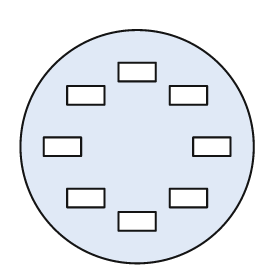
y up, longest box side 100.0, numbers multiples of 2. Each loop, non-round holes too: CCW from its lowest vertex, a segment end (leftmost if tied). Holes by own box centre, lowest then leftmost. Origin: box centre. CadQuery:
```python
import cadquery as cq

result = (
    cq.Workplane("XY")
    .moveTo(0.0, 0.0)
    .circle(50.0)
    .moveTo(-8.0, -36.0)
    .lineTo(8.0, -36.0)
    .lineTo(8.0, -28.0)
    .lineTo(-8.0, -28.0)
    .close()
    .moveTo(-30.0, -26.0)
    .lineTo(-14.0, -26.0)
    .lineTo(-14.0, -18.0)
    .lineTo(-30.0, -18.0)
    .close()
    .moveTo(14.0, -26.0)
    .lineTo(30.0, -26.0)
    .lineTo(30.0, -18.0)
    .lineTo(14.0, -18.0)
    .close()
    .moveTo(-40.0, -4.0)
    .lineTo(-24.0, -4.0)
    .lineTo(-24.0, 4.0)
    .lineTo(-40.0, 4.0)
    .close()
    .moveTo(24.0, -4.0)
    .lineTo(40.0, -4.0)
    .lineTo(40.0, 4.0)
    .lineTo(24.0, 4.0)
    .close()
    .moveTo(-30.0, 18.0)
    .lineTo(-14.0, 18.0)
    .lineTo(-14.0, 26.0)
    .lineTo(-30.0, 26.0)
    .close()
    .moveTo(14.0, 18.0)
    .lineTo(30.0, 18.0)
    .lineTo(30.0, 26.0)
    .lineTo(14.0, 26.0)
    .close()
    .moveTo(-8.0, 28.0)
    .lineTo(8.0, 28.0)
    .lineTo(8.0, 36.0)
    .lineTo(-8.0, 36.0)
    .close()
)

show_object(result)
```